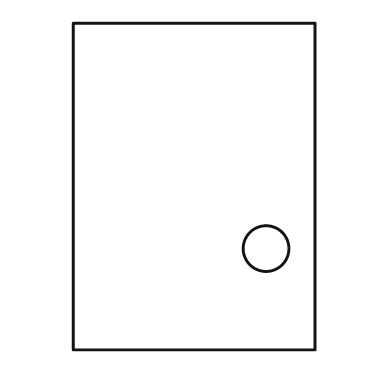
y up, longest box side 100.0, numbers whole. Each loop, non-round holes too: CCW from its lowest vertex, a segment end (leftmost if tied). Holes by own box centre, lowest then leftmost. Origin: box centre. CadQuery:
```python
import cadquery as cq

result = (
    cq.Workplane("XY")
    .moveTo(-37.0, -50.0)
    .lineTo(37.0, -50.0)
    .lineTo(37.0, 50.0)
    .lineTo(-37.0, 50.0)
    .close()
    .moveTo(22.0, -19.0)
    .circle(7.0)
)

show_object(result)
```